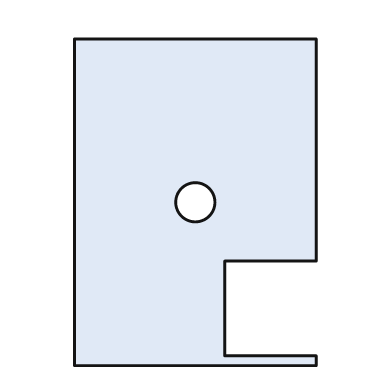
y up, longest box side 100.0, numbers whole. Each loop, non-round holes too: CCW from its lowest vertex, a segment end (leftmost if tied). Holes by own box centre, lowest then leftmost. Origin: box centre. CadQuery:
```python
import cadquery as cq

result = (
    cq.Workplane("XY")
    .moveTo(-37.0, -50.0)
    .lineTo(37.0, -50.0)
    .lineTo(37.0, -47.0)
    .lineTo(9.0, -47.0)
    .lineTo(9.0, -18.0)
    .lineTo(37.0, -18.0)
    .lineTo(37.0, 50.0)
    .lineTo(-37.0, 50.0)
    .close()
    .moveTo(0.0, 0.0)
    .circle(6.0)
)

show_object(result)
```